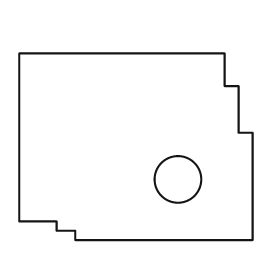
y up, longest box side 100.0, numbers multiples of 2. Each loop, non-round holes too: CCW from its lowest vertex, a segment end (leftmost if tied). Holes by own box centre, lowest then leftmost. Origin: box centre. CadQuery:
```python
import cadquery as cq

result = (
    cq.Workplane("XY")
    .moveTo(-26.0, -40.0)
    .lineTo(50.0, -40.0)
    .lineTo(50.0, 6.0)
    .lineTo(44.0, 6.0)
    .lineTo(44.0, 26.0)
    .lineTo(38.0, 26.0)
    .lineTo(38.0, 40.0)
    .lineTo(-50.0, 40.0)
    .lineTo(-50.0, -32.0)
    .lineTo(-34.0, -32.0)
    .lineTo(-34.0, -36.0)
    .lineTo(-26.0, -36.0)
    .close()
    .moveTo(18.0, -14.0)
    .circle(10.0)
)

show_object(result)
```